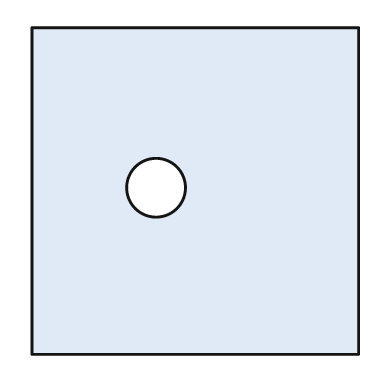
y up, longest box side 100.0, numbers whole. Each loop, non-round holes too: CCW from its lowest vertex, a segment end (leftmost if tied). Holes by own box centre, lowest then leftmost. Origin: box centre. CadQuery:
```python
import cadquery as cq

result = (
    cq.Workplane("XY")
    .moveTo(-50.0, -50.0)
    .lineTo(50.0, -50.0)
    .lineTo(50.0, 50.0)
    .lineTo(-50.0, 50.0)
    .close()
    .moveTo(-12.0, 1.0)
    .circle(9.0)
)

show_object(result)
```